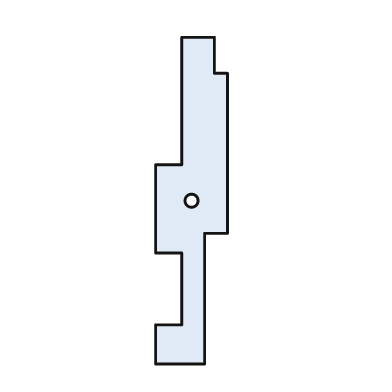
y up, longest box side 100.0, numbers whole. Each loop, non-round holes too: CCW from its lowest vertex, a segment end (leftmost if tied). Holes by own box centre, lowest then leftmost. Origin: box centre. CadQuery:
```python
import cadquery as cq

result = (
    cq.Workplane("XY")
    .moveTo(-11.0, -50.0)
    .lineTo(4.0, -50.0)
    .lineTo(4.0, -10.0)
    .lineTo(11.0, -10.0)
    .lineTo(11.0, 39.0)
    .lineTo(7.0, 39.0)
    .lineTo(7.0, 50.0)
    .lineTo(-3.0, 50.0)
    .lineTo(-3.0, 11.0)
    .lineTo(-11.0, 11.0)
    .lineTo(-11.0, -16.0)
    .lineTo(-3.0, -16.0)
    .lineTo(-3.0, -38.0)
    .lineTo(-11.0, -38.0)
    .close()
    .moveTo(0.0, 0.0)
    .circle(2.0)
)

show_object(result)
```